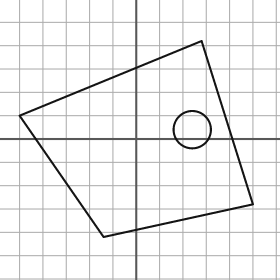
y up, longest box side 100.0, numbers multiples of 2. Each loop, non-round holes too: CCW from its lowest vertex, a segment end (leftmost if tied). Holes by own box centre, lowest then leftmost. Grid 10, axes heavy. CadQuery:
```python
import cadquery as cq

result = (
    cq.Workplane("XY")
    .moveTo(-14.0, -42.0)
    .lineTo(50.0, -28.0)
    .lineTo(28.0, 42.0)
    .lineTo(-50.0, 10.0)
    .close()
    .moveTo(24.0, 4.0)
    .circle(8.0)
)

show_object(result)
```